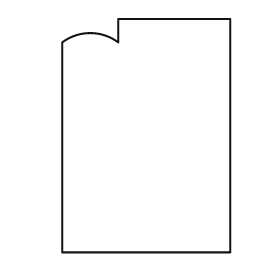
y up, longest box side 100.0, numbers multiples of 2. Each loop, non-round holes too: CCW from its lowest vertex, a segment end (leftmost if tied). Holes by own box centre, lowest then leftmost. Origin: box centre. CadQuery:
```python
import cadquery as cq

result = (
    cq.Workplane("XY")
    .moveTo(-36.0, -50.0)
    .lineTo(36.0, -50.0)
    .lineTo(36.0, 50.0)
    .lineTo(-12.0, 50.0)
    .lineTo(-12.0, 40.0)
    .threePointArc((-24.0, 44.0), (-36.0, 40.0))
    .close()
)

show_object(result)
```